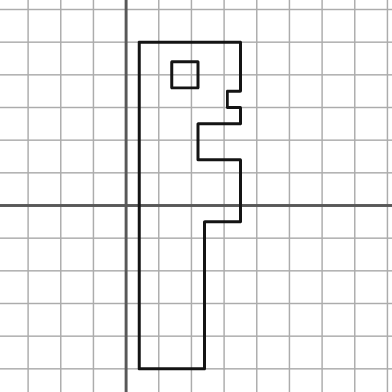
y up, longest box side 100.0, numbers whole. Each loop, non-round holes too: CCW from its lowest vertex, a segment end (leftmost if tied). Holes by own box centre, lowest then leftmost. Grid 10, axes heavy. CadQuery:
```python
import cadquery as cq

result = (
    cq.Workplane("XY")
    .moveTo(4.0, -50.0)
    .lineTo(24.0, -50.0)
    .lineTo(24.0, -5.0)
    .lineTo(35.0, -5.0)
    .lineTo(35.0, 14.0)
    .lineTo(22.0, 14.0)
    .lineTo(22.0, 25.0)
    .lineTo(35.0, 25.0)
    .lineTo(35.0, 30.0)
    .lineTo(31.0, 30.0)
    .lineTo(31.0, 35.0)
    .lineTo(35.0, 35.0)
    .lineTo(35.0, 50.0)
    .lineTo(4.0, 50.0)
    .close()
    .moveTo(14.0, 36.0)
    .lineTo(22.0, 36.0)
    .lineTo(22.0, 44.0)
    .lineTo(14.0, 44.0)
    .close()
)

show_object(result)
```